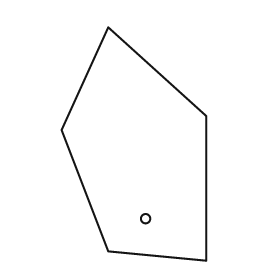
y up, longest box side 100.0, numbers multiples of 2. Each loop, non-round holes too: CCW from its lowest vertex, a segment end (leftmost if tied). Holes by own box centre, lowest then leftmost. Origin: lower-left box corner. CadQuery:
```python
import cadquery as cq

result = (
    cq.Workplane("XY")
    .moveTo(62.0, 0.0)
    .lineTo(62.0, 62.0)
    .lineTo(20.0, 100.0)
    .lineTo(0.0, 56.0)
    .lineTo(20.0, 4.0)
    .close()
    .moveTo(36.0, 18.0)
    .circle(2.0)
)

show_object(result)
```